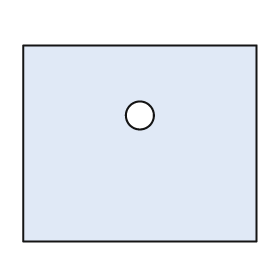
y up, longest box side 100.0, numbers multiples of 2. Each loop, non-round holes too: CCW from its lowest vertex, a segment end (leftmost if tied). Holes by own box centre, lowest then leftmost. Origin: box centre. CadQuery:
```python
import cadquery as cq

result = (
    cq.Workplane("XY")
    .moveTo(-50.0, -42.0)
    .lineTo(50.0, -42.0)
    .lineTo(50.0, 42.0)
    .lineTo(-50.0, 42.0)
    .close()
    .moveTo(0.0, 12.0)
    .circle(6.0)
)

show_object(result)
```